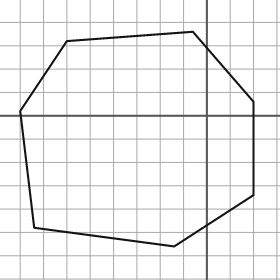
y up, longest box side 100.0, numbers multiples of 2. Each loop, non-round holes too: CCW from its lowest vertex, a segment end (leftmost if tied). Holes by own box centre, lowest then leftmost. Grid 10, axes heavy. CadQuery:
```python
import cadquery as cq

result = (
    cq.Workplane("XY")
    .moveTo(-14.0, -56.0)
    .lineTo(20.0, -34.0)
    .lineTo(20.0, 6.0)
    .lineTo(-6.0, 36.0)
    .lineTo(-60.0, 32.0)
    .lineTo(-80.0, 2.0)
    .lineTo(-74.0, -48.0)
    .close()
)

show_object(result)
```